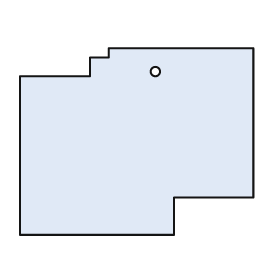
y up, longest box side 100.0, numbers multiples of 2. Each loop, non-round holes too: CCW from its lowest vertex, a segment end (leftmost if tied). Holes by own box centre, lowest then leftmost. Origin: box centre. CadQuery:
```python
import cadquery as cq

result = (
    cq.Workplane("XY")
    .moveTo(-50.0, -40.0)
    .lineTo(16.0, -40.0)
    .lineTo(16.0, -24.0)
    .lineTo(50.0, -24.0)
    .lineTo(50.0, 40.0)
    .lineTo(-12.0, 40.0)
    .lineTo(-12.0, 36.0)
    .lineTo(-20.0, 36.0)
    .lineTo(-20.0, 28.0)
    .lineTo(-50.0, 28.0)
    .close()
    .moveTo(8.0, 30.0)
    .circle(2.0)
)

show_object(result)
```